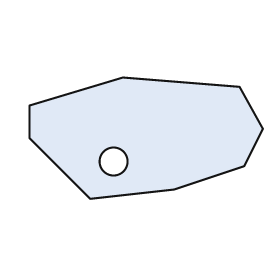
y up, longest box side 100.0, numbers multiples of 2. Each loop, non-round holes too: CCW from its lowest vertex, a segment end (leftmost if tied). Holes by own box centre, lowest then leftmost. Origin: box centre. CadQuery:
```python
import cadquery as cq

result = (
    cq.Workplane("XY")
    .moveTo(-24.0, -26.0)
    .lineTo(12.0, -22.0)
    .lineTo(42.0, -12.0)
    .lineTo(50.0, 4.0)
    .lineTo(40.0, 22.0)
    .lineTo(-10.0, 26.0)
    .lineTo(-50.0, 14.0)
    .lineTo(-50.0, 0.0)
    .close()
    .moveTo(-14.0, -10.0)
    .circle(6.0)
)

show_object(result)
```